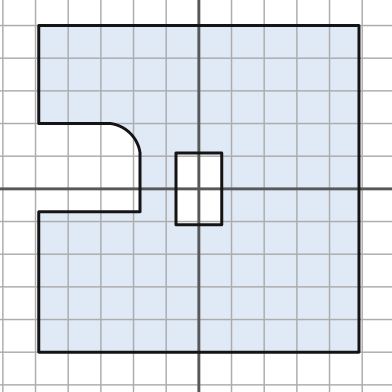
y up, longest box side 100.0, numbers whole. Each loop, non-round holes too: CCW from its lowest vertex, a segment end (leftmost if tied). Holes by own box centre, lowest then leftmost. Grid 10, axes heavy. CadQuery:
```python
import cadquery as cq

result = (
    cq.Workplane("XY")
    .moveTo(-49.0, -50.0)
    .lineTo(49.0, -50.0)
    .lineTo(49.0, 50.0)
    .lineTo(-49.0, 50.0)
    .lineTo(-49.0, 20.0)
    .lineTo(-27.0, 20.0)
    .threePointArc((-21.0, 17.0), (-18.0, 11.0))
    .lineTo(-18.0, -7.0)
    .lineTo(-49.0, -7.0)
    .close()
    .moveTo(-7.0, -11.0)
    .lineTo(7.0, -11.0)
    .lineTo(7.0, 11.0)
    .lineTo(-7.0, 11.0)
    .close()
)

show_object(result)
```